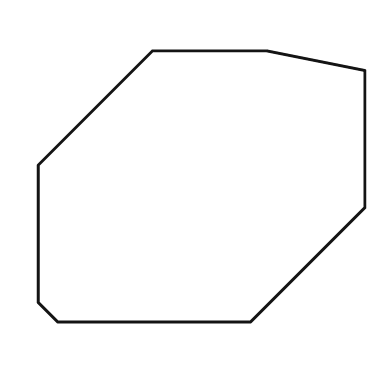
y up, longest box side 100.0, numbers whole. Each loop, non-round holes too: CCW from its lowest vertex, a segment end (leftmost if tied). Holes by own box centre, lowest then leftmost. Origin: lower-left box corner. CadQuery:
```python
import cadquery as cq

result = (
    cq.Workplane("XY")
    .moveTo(6.0, 0.0)
    .lineTo(65.0, 0.0)
    .lineTo(100.0, 35.0)
    .lineTo(100.0, 77.0)
    .lineTo(70.0, 83.0)
    .lineTo(35.0, 83.0)
    .lineTo(0.0, 48.0)
    .lineTo(0.0, 6.0)
    .close()
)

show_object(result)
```